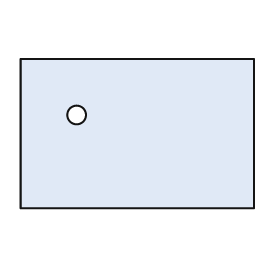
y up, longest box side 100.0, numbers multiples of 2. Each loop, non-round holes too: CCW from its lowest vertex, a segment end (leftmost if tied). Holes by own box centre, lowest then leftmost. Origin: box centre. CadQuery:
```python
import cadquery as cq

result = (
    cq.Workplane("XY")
    .moveTo(-50.0, -32.0)
    .lineTo(50.0, -32.0)
    .lineTo(50.0, 32.0)
    .lineTo(-50.0, 32.0)
    .close()
    .moveTo(-26.0, 8.0)
    .circle(4.0)
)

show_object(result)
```